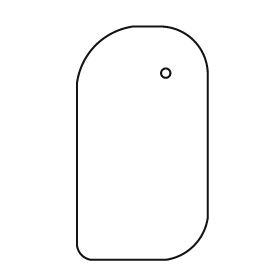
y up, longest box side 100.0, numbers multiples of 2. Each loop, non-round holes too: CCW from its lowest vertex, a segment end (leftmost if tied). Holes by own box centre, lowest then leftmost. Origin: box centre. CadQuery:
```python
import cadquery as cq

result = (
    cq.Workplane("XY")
    .moveTo(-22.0, -50.0)
    .lineTo(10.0, -50.0)
    .threePointArc((22.0, -44.0), (28.0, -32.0))
    .lineTo(28.0, 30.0)
    .threePointArc((22.0, 44.0), (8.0, 50.0))
    .lineTo(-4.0, 50.0)
    .threePointArc((-20.0, 42.0), (-28.0, 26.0))
    .lineTo(-28.0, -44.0)
    .threePointArc((-26.0, -48.0), (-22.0, -50.0))
    .close()
    .moveTo(10.0, 30.0)
    .circle(2.0)
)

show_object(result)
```